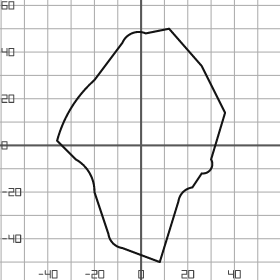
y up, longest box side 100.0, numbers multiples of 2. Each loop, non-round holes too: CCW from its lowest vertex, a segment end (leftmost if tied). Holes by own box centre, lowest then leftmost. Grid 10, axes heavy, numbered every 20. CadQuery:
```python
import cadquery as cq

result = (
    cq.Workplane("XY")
    .moveTo(8.0, -50.0)
    .lineTo(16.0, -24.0)
    .threePointArc((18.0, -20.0), (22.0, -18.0))
    .lineTo(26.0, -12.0)
    .threePointArc((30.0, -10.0), (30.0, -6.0))
    .lineTo(36.0, 14.0)
    .lineTo(26.0, 34.0)
    .lineTo(12.0, 50.0)
    .lineTo(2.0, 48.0)
    .threePointArc((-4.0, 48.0), (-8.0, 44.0))
    .lineTo(-20.0, 28.0)
    .threePointArc((-30.0, 16.0), (-36.0, 2.0))
    .lineTo(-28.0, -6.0)
    .threePointArc((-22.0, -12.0), (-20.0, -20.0))
    .lineTo(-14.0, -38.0)
    .threePointArc((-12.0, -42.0), (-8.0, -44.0))
    .close()
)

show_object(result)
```